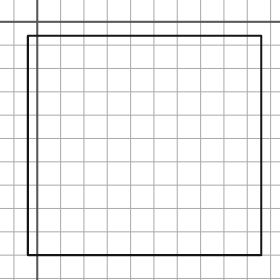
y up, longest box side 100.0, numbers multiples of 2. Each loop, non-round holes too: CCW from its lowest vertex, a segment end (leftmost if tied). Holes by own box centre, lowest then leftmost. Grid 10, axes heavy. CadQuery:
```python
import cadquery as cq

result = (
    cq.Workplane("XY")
    .moveTo(-4.0, -100.0)
    .lineTo(96.0, -100.0)
    .lineTo(96.0, -6.0)
    .lineTo(-4.0, -6.0)
    .close()
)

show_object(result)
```